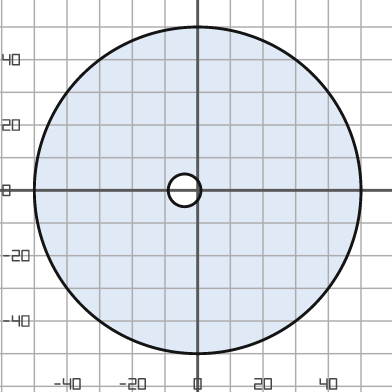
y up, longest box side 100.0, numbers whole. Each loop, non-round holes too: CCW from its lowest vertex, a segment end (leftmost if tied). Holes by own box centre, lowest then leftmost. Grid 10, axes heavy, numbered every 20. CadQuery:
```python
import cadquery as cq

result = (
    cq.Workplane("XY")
    .moveTo(0.0, 0.0)
    .circle(50.0)
    .moveTo(-4.0, 0.0)
    .circle(5.0)
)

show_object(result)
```